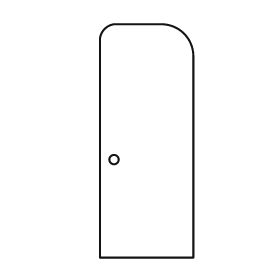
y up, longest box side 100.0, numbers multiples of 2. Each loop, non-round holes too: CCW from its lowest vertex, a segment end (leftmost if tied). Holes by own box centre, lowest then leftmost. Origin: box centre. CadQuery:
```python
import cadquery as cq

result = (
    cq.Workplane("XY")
    .moveTo(-20.0, -50.0)
    .lineTo(20.0, -50.0)
    .lineTo(20.0, 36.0)
    .threePointArc((16.0, 46.0), (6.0, 50.0))
    .lineTo(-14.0, 50.0)
    .threePointArc((-18.0, 48.0), (-20.0, 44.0))
    .close()
    .moveTo(-14.0, -8.0)
    .circle(2.0)
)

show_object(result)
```